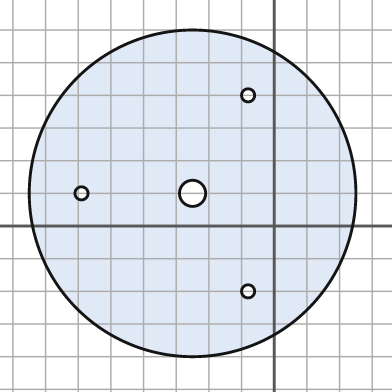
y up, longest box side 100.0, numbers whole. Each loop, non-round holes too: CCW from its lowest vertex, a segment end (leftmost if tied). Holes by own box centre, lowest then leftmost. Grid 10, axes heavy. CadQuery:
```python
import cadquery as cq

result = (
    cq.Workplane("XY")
    .moveTo(-25.0, 10.0)
    .circle(50.0)
    .moveTo(-8.0, -20.0)
    .circle(2.0)
    .moveTo(-59.0, 10.0)
    .circle(2.0)
    .moveTo(-25.0, 10.0)
    .circle(4.0)
    .moveTo(-8.0, 40.0)
    .circle(2.0)
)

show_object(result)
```